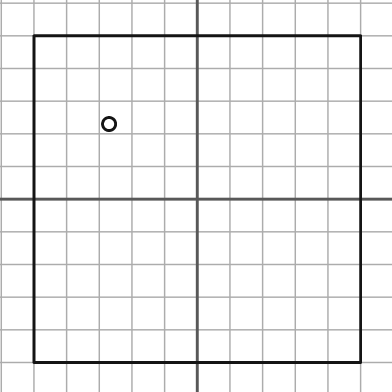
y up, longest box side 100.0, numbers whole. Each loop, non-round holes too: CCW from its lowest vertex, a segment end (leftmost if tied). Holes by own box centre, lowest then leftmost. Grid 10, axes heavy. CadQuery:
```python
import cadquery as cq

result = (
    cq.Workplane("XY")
    .moveTo(-50.0, -50.0)
    .lineTo(50.0, -50.0)
    .lineTo(50.0, 50.0)
    .lineTo(-50.0, 50.0)
    .close()
    .moveTo(-27.0, 23.0)
    .circle(2.0)
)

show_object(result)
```